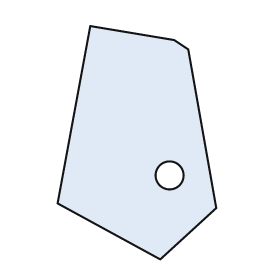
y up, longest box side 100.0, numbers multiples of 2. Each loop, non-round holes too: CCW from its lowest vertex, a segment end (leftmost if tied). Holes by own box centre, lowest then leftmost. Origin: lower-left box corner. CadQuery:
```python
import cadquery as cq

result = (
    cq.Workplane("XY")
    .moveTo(44.0, 0.0)
    .lineTo(68.0, 22.0)
    .lineTo(56.0, 90.0)
    .lineTo(50.0, 94.0)
    .lineTo(14.0, 100.0)
    .lineTo(0.0, 24.0)
    .close()
    .moveTo(48.0, 36.0)
    .circle(6.0)
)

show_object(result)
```